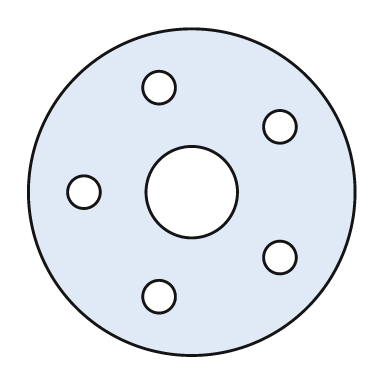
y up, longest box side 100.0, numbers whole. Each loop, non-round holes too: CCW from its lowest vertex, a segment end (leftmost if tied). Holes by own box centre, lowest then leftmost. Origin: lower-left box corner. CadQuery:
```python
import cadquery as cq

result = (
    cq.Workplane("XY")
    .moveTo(50.0, 50.0)
    .circle(50.0)
    .moveTo(40.0, 18.0)
    .circle(5.0)
    .moveTo(77.0, 30.0)
    .circle(5.0)
    .moveTo(17.0, 50.0)
    .circle(5.0)
    .moveTo(50.0, 50.0)
    .circle(14.0)
    .moveTo(77.0, 70.0)
    .circle(5.0)
    .moveTo(40.0, 82.0)
    .circle(5.0)
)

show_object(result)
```